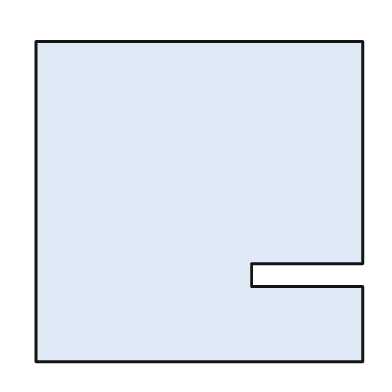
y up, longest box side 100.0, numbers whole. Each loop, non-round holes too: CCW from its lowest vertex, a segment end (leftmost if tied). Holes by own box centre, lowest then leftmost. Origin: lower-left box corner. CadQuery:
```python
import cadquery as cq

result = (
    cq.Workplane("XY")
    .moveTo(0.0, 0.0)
    .lineTo(100.0, 0.0)
    .lineTo(100.0, 23.0)
    .lineTo(66.0, 23.0)
    .lineTo(66.0, 30.0)
    .lineTo(100.0, 30.0)
    .lineTo(100.0, 98.0)
    .lineTo(0.0, 98.0)
    .close()
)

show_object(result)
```